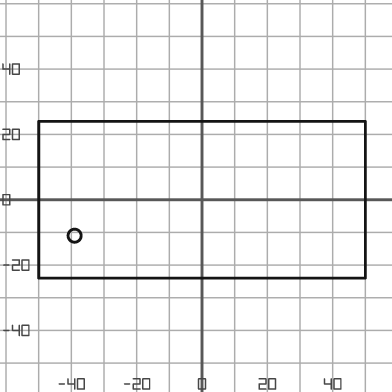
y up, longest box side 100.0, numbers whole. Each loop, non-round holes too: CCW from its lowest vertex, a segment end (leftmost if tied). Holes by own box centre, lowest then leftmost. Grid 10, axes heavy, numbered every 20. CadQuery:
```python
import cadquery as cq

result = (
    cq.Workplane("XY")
    .moveTo(-50.0, -24.0)
    .lineTo(50.0, -24.0)
    .lineTo(50.0, 24.0)
    .lineTo(-50.0, 24.0)
    .close()
    .moveTo(-39.0, -11.0)
    .circle(2.0)
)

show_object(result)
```